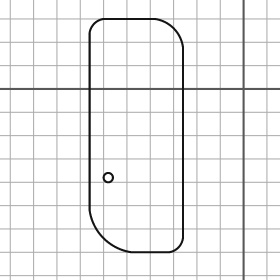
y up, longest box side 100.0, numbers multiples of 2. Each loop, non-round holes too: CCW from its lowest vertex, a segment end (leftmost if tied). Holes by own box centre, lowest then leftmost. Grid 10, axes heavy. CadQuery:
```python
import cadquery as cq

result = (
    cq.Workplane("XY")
    .moveTo(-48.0, -70.0)
    .lineTo(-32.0, -70.0)
    .threePointArc((-28.0, -68.0), (-26.0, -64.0))
    .lineTo(-26.0, 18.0)
    .threePointArc((-30.0, 26.0), (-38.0, 30.0))
    .lineTo(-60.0, 30.0)
    .threePointArc((-64.0, 28.0), (-66.0, 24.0))
    .lineTo(-66.0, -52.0)
    .threePointArc((-60.0, -64.0), (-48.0, -70.0))
    .close()
    .moveTo(-58.0, -38.0)
    .circle(2.0)
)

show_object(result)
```